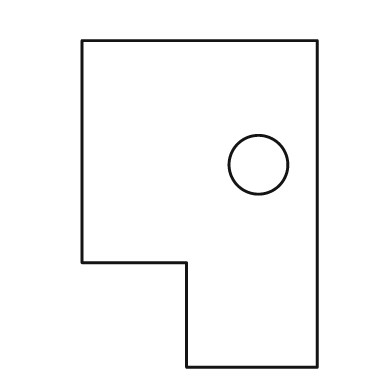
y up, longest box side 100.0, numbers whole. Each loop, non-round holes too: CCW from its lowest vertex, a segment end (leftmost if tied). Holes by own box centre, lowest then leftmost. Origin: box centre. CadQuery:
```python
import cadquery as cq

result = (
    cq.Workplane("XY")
    .moveTo(-4.0, -50.0)
    .lineTo(36.0, -50.0)
    .lineTo(36.0, 50.0)
    .lineTo(-36.0, 50.0)
    .lineTo(-36.0, -18.0)
    .lineTo(-4.0, -18.0)
    .close()
    .moveTo(18.0, 12.0)
    .circle(9.0)
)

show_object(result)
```